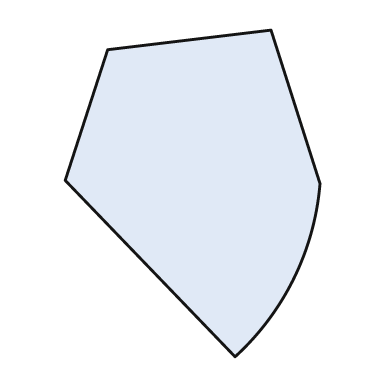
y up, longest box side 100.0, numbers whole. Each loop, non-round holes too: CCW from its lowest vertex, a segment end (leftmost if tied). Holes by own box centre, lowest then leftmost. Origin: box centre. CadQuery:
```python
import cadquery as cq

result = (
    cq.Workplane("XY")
    .moveTo(13.0, -50.0)
    .threePointArc((31.0, -26.0), (39.0, 3.0))
    .lineTo(24.0, 50.0)
    .lineTo(-26.0, 44.0)
    .lineTo(-39.0, 4.0)
    .close()
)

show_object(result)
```